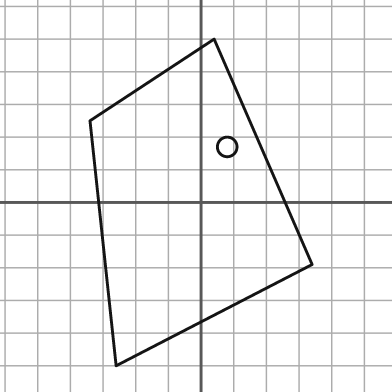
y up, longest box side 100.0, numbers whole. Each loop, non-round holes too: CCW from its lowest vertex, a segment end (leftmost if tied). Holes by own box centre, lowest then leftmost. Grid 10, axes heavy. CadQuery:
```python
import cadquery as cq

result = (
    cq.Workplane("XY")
    .moveTo(-26.0, -50.0)
    .lineTo(34.0, -19.0)
    .lineTo(4.0, 50.0)
    .lineTo(-34.0, 25.0)
    .close()
    .moveTo(8.0, 17.0)
    .circle(3.0)
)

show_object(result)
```